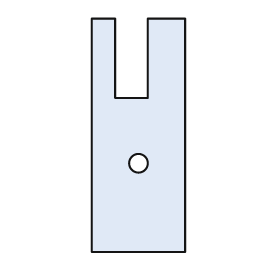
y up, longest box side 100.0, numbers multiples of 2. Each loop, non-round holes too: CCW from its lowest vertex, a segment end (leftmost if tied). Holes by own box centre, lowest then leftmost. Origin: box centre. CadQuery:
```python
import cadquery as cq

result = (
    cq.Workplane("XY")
    .moveTo(-20.0, -50.0)
    .lineTo(20.0, -50.0)
    .lineTo(20.0, 50.0)
    .lineTo(4.0, 50.0)
    .lineTo(4.0, 16.0)
    .lineTo(-10.0, 16.0)
    .lineTo(-10.0, 50.0)
    .lineTo(-20.0, 50.0)
    .close()
    .moveTo(0.0, -12.0)
    .circle(4.0)
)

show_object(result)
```